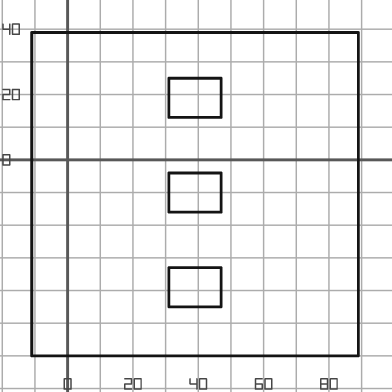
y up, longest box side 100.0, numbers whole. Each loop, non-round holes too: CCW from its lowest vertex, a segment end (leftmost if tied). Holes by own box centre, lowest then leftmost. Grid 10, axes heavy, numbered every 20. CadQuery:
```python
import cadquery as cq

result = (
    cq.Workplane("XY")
    .moveTo(-11.0, -60.0)
    .lineTo(89.0, -60.0)
    .lineTo(89.0, 39.0)
    .lineTo(-11.0, 39.0)
    .close()
    .moveTo(31.0, -45.0)
    .lineTo(47.0, -45.0)
    .lineTo(47.0, -33.0)
    .lineTo(31.0, -33.0)
    .close()
    .moveTo(31.0, -16.0)
    .lineTo(47.0, -16.0)
    .lineTo(47.0, -4.0)
    .lineTo(31.0, -4.0)
    .close()
    .moveTo(31.0, 13.0)
    .lineTo(47.0, 13.0)
    .lineTo(47.0, 25.0)
    .lineTo(31.0, 25.0)
    .close()
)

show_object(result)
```